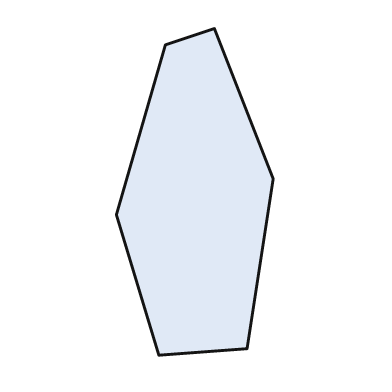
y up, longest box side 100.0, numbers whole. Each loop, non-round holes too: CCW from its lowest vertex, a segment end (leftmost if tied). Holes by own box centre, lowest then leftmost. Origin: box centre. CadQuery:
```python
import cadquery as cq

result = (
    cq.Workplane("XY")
    .moveTo(-11.0, -50.0)
    .lineTo(16.0, -48.0)
    .lineTo(24.0, 4.0)
    .lineTo(6.0, 50.0)
    .lineTo(-9.0, 45.0)
    .lineTo(-24.0, -7.0)
    .close()
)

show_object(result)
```